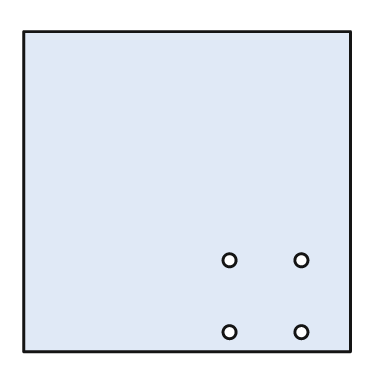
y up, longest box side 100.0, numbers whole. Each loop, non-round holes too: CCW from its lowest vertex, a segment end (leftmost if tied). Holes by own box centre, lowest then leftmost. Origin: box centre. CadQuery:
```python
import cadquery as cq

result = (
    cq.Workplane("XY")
    .moveTo(-50.0, -49.0)
    .lineTo(50.0, -49.0)
    .lineTo(50.0, 49.0)
    .lineTo(-50.0, 49.0)
    .close()
    .moveTo(13.0, -43.0)
    .circle(2.0)
    .moveTo(35.0, -43.0)
    .circle(2.0)
    .moveTo(13.0, -21.0)
    .circle(2.0)
    .moveTo(35.0, -21.0)
    .circle(2.0)
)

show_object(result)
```